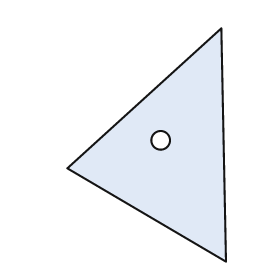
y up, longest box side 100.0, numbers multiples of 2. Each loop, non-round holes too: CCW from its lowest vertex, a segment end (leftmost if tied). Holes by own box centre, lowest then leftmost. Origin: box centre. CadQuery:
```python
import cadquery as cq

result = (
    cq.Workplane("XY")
    .moveTo(34.0, -50.0)
    .lineTo(32.0, 50.0)
    .lineTo(-34.0, -10.0)
    .close()
    .moveTo(6.0, 2.0)
    .circle(4.0)
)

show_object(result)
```